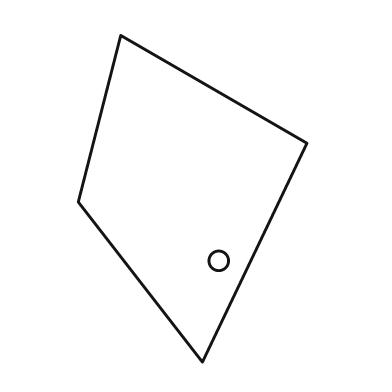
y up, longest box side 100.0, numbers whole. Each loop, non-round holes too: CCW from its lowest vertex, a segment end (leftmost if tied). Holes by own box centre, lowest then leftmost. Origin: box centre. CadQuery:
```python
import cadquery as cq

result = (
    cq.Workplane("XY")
    .moveTo(3.0, -50.0)
    .lineTo(35.0, 17.0)
    .lineTo(-22.0, 50.0)
    .lineTo(-35.0, -1.0)
    .close()
    .moveTo(8.0, -19.0)
    .circle(3.0)
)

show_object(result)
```